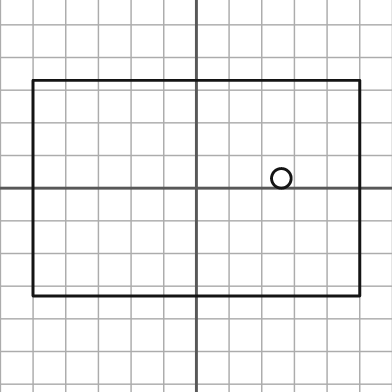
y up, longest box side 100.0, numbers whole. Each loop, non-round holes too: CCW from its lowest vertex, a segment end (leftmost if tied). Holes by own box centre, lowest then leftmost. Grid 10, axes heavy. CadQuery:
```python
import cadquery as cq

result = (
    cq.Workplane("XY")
    .moveTo(-50.0, -33.0)
    .lineTo(50.0, -33.0)
    .lineTo(50.0, 33.0)
    .lineTo(-50.0, 33.0)
    .close()
    .moveTo(26.0, 3.0)
    .circle(3.0)
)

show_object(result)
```